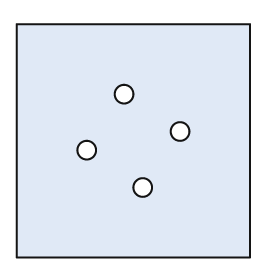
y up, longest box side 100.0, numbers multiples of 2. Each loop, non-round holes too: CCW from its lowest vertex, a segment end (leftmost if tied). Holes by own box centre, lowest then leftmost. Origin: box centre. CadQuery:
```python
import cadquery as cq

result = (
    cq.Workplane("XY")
    .moveTo(-50.0, -50.0)
    .lineTo(50.0, -50.0)
    .lineTo(50.0, 50.0)
    .lineTo(-50.0, 50.0)
    .close()
    .moveTo(4.0, -20.0)
    .circle(4.0)
    .moveTo(-20.0, -4.0)
    .circle(4.0)
    .moveTo(20.0, 4.0)
    .circle(4.0)
    .moveTo(-4.0, 20.0)
    .circle(4.0)
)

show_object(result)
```